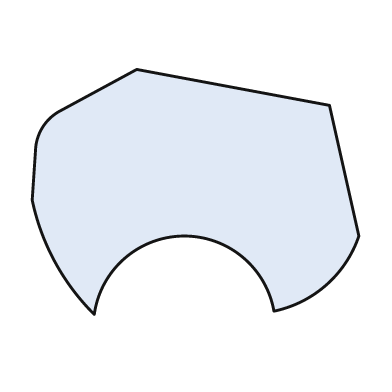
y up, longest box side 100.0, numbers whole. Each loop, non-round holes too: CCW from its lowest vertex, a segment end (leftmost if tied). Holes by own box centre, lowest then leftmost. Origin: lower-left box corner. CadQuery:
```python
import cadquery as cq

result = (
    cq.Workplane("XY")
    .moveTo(19.0, 0.0)
    .threePointArc((46.0, 24.0), (74.0, 1.0))
    .threePointArc((90.0, 9.0), (100.0, 24.0))
    .lineTo(91.0, 64.0)
    .lineTo(32.0, 75.0)
    .lineTo(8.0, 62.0)
    .threePointArc((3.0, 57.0), (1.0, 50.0))
    .lineTo(0.0, 35.0)
    .threePointArc((7.0, 16.0), (19.0, 0.0))
    .close()
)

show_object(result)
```